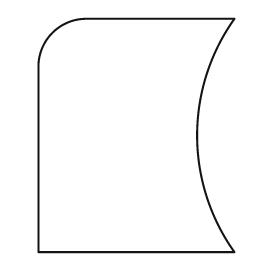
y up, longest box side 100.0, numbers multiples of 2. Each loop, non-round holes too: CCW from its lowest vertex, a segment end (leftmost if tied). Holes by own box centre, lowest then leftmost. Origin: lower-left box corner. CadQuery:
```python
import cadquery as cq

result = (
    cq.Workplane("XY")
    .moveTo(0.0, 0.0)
    .lineTo(84.0, 0.0)
    .threePointArc((68.0, 50.0), (84.0, 100.0))
    .lineTo(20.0, 100.0)
    .threePointArc((6.0, 94.0), (0.0, 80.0))
    .close()
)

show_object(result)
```